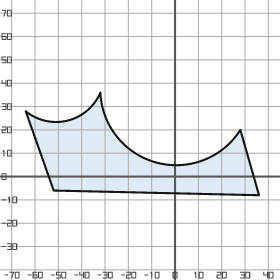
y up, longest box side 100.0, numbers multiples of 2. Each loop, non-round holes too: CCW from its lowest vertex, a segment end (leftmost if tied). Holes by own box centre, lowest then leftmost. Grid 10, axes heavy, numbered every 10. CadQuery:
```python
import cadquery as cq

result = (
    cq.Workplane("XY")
    .moveTo(36.0, -8.0)
    .lineTo(28.0, 20.0)
    .threePointArc((-8.0, 6.0), (-32.0, 36.0))
    .threePointArc((-46.0, 24.0), (-64.0, 28.0))
    .lineTo(-52.0, -6.0)
    .close()
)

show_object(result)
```